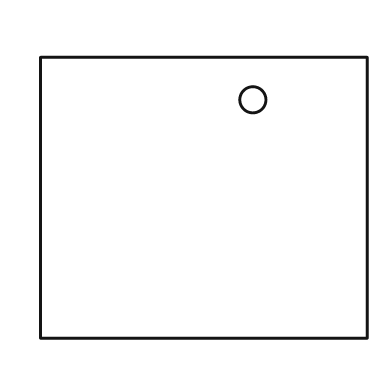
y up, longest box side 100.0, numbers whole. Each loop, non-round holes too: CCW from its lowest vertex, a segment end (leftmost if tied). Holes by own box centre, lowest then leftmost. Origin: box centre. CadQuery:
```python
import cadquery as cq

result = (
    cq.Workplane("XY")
    .moveTo(-50.0, -43.0)
    .lineTo(50.0, -43.0)
    .lineTo(50.0, 43.0)
    .lineTo(-50.0, 43.0)
    .close()
    .moveTo(15.0, 30.0)
    .circle(4.0)
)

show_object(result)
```